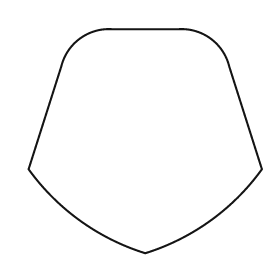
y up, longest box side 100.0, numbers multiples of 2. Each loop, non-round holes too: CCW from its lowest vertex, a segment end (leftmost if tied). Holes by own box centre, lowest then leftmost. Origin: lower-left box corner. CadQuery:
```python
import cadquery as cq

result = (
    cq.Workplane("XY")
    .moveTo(50.0, 0.0)
    .threePointArc((78.0, 14.0), (100.0, 36.0))
    .lineTo(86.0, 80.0)
    .threePointArc((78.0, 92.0), (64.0, 96.0))
    .lineTo(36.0, 96.0)
    .threePointArc((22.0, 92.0), (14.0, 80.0))
    .lineTo(0.0, 36.0)
    .threePointArc((22.0, 14.0), (50.0, 0.0))
    .close()
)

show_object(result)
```